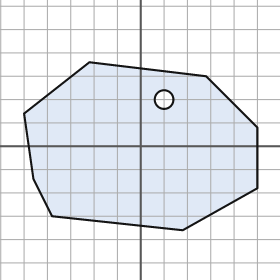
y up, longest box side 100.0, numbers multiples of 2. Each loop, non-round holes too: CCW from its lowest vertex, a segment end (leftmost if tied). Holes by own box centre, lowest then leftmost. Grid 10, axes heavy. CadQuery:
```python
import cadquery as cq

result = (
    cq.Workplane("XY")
    .moveTo(18.0, -36.0)
    .lineTo(50.0, -18.0)
    .lineTo(50.0, 8.0)
    .lineTo(28.0, 30.0)
    .lineTo(-22.0, 36.0)
    .lineTo(-50.0, 14.0)
    .lineTo(-46.0, -14.0)
    .lineTo(-38.0, -30.0)
    .close()
    .moveTo(10.0, 20.0)
    .circle(4.0)
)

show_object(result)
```